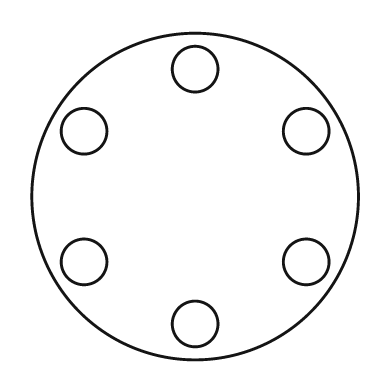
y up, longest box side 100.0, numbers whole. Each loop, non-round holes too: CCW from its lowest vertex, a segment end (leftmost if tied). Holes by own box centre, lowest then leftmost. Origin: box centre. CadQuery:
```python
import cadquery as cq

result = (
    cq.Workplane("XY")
    .moveTo(0.0, 0.0)
    .circle(50.0)
    .moveTo(0.0, -39.0)
    .circle(7.0)
    .moveTo(-34.0, -20.0)
    .circle(7.0)
    .moveTo(34.0, -20.0)
    .circle(7.0)
    .moveTo(-34.0, 20.0)
    .circle(7.0)
    .moveTo(34.0, 20.0)
    .circle(7.0)
    .moveTo(0.0, 39.0)
    .circle(7.0)
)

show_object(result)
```